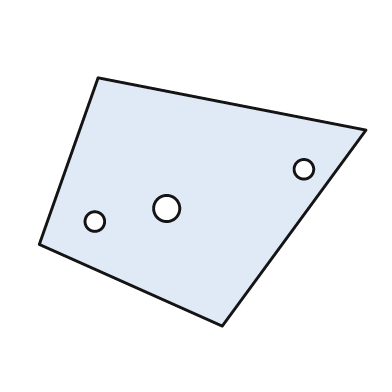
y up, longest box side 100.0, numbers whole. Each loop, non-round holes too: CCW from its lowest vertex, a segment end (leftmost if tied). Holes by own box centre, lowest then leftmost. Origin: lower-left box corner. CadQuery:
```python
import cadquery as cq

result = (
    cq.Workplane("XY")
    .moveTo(56.0, 0.0)
    .lineTo(100.0, 60.0)
    .lineTo(18.0, 76.0)
    .lineTo(0.0, 25.0)
    .close()
    .moveTo(17.0, 32.0)
    .circle(3.0)
    .moveTo(39.0, 36.0)
    .circle(4.0)
    .moveTo(81.0, 48.0)
    .circle(3.0)
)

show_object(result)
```